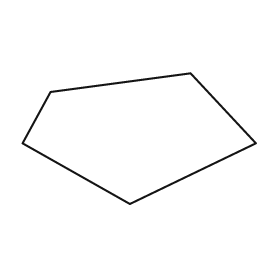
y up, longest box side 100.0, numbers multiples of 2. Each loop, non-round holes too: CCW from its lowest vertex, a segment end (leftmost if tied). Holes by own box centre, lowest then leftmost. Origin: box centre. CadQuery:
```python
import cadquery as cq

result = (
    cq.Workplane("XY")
    .moveTo(-4.0, -28.0)
    .lineTo(50.0, -2.0)
    .lineTo(22.0, 28.0)
    .lineTo(-38.0, 20.0)
    .lineTo(-50.0, -2.0)
    .close()
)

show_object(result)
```